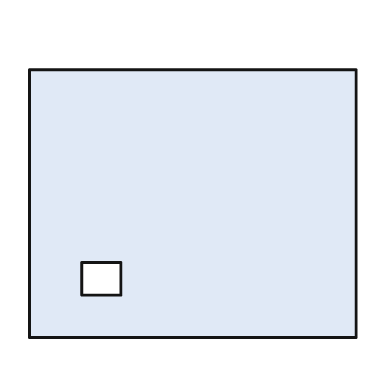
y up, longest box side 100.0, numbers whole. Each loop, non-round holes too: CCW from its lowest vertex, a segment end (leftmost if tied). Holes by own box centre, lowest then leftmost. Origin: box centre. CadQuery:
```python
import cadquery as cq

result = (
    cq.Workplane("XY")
    .moveTo(-50.0, -41.0)
    .lineTo(50.0, -41.0)
    .lineTo(50.0, 41.0)
    .lineTo(-50.0, 41.0)
    .close()
    .moveTo(-34.0, -28.0)
    .lineTo(-22.0, -28.0)
    .lineTo(-22.0, -18.0)
    .lineTo(-34.0, -18.0)
    .close()
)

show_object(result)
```